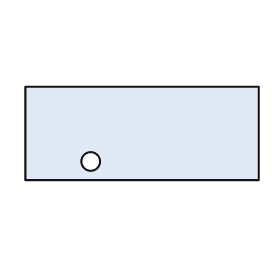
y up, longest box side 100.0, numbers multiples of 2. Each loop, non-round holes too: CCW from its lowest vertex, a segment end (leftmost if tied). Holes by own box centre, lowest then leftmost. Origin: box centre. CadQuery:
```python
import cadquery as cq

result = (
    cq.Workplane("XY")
    .moveTo(-50.0, -20.0)
    .lineTo(50.0, -20.0)
    .lineTo(50.0, 20.0)
    .lineTo(-50.0, 20.0)
    .close()
    .moveTo(-22.0, -12.0)
    .circle(4.0)
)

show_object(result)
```